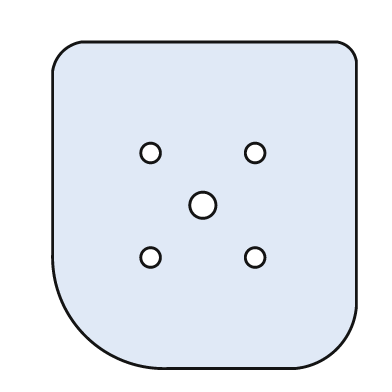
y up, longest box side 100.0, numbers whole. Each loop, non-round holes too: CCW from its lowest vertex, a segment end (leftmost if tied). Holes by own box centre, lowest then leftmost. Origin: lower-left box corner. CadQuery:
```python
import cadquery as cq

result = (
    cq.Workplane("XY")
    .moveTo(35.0, 0.0)
    .lineTo(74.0, 0.0)
    .threePointArc((87.0, 6.0), (93.0, 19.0))
    .lineTo(93.0, 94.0)
    .threePointArc((91.0, 98.0), (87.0, 100.0))
    .lineTo(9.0, 100.0)
    .threePointArc((3.0, 97.0), (0.0, 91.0))
    .lineTo(0.0, 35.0)
    .threePointArc((10.0, 10.0), (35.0, 0.0))
    .close()
    .moveTo(30.0, 34.0)
    .circle(3.0)
    .moveTo(62.0, 34.0)
    .circle(3.0)
    .moveTo(46.0, 50.0)
    .circle(4.0)
    .moveTo(30.0, 66.0)
    .circle(3.0)
    .moveTo(62.0, 66.0)
    .circle(3.0)
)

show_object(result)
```